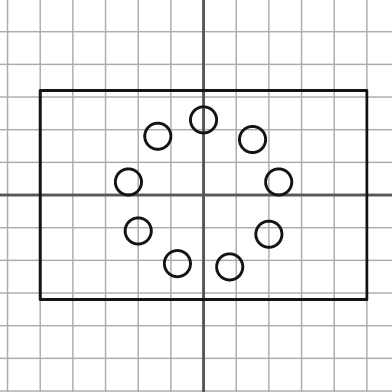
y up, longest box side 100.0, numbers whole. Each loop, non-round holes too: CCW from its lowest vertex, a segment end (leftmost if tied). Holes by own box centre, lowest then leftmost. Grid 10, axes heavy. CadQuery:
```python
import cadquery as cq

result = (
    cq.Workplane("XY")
    .moveTo(-50.0, -32.0)
    .lineTo(50.0, -32.0)
    .lineTo(50.0, 32.0)
    .lineTo(-50.0, 32.0)
    .close()
    .moveTo(8.0, -22.0)
    .circle(4.0)
    .moveTo(-8.0, -21.0)
    .circle(4.0)
    .moveTo(20.0, -12.0)
    .circle(4.0)
    .moveTo(-20.0, -11.0)
    .circle(4.0)
    .moveTo(-23.0, 4.0)
    .circle(4.0)
    .moveTo(23.0, 4.0)
    .circle(4.0)
    .moveTo(15.0, 17.0)
    .circle(4.0)
    .moveTo(-14.0, 18.0)
    .circle(4.0)
    .moveTo(0.0, 23.0)
    .circle(4.0)
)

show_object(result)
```